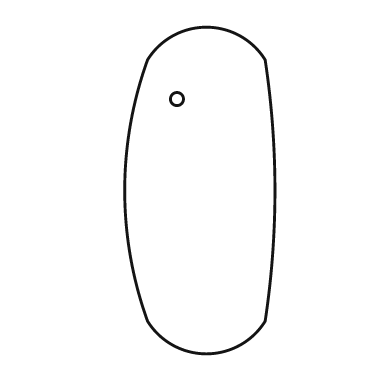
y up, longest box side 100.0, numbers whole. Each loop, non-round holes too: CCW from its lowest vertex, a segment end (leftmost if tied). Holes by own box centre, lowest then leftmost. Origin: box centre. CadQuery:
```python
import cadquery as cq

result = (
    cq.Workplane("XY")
    .moveTo(-16.0, -40.0)
    .threePointArc((2.0, -50.0), (20.0, -40.0))
    .threePointArc((23.0, 0.0), (20.0, 40.0))
    .threePointArc((2.0, 50.0), (-16.0, 40.0))
    .threePointArc((-23.0, 0.0), (-16.0, -40.0))
    .close()
    .moveTo(-7.0, 28.0)
    .circle(2.0)
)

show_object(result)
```